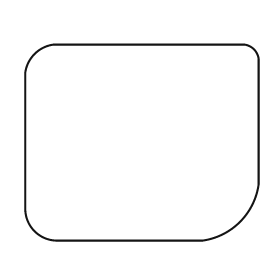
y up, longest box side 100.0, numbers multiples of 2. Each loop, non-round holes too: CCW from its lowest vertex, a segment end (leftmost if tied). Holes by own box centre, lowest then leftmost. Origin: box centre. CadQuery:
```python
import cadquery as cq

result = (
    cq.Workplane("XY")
    .moveTo(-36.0, -42.0)
    .lineTo(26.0, -42.0)
    .threePointArc((42.0, -34.0), (50.0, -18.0))
    .lineTo(50.0, 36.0)
    .threePointArc((48.0, 40.0), (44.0, 42.0))
    .lineTo(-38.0, 42.0)
    .threePointArc((-46.0, 38.0), (-50.0, 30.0))
    .lineTo(-50.0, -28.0)
    .threePointArc((-46.0, -38.0), (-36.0, -42.0))
    .close()
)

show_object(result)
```